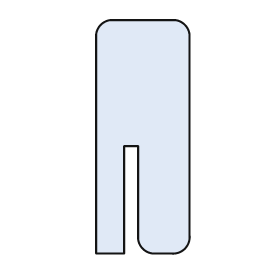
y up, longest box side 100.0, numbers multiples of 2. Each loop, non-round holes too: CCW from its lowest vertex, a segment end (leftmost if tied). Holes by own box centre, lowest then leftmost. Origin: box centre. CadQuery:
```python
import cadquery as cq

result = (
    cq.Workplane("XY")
    .moveTo(-20.0, -50.0)
    .lineTo(-8.0, -50.0)
    .lineTo(-8.0, -4.0)
    .lineTo(-2.0, -4.0)
    .lineTo(-2.0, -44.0)
    .threePointArc((0.0, -48.0), (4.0, -50.0))
    .lineTo(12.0, -50.0)
    .threePointArc((18.0, -48.0), (20.0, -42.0))
    .lineTo(20.0, 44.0)
    .threePointArc((18.0, 48.0), (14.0, 50.0))
    .lineTo(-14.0, 50.0)
    .threePointArc((-18.0, 48.0), (-20.0, 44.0))
    .close()
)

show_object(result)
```